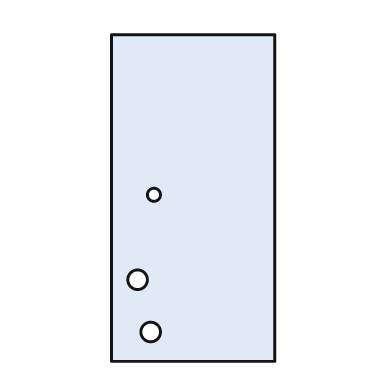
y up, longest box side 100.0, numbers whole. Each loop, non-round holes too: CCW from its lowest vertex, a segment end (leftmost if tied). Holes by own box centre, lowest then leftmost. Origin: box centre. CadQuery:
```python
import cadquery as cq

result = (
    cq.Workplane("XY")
    .moveTo(-25.0, -50.0)
    .lineTo(25.0, -50.0)
    .lineTo(25.0, 50.0)
    .lineTo(-25.0, 50.0)
    .close()
    .moveTo(-13.0, -41.0)
    .circle(3.0)
    .moveTo(-17.0, -25.0)
    .circle(3.0)
    .moveTo(-12.0, 1.0)
    .circle(2.0)
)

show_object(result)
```